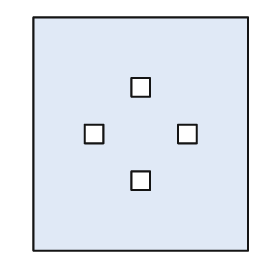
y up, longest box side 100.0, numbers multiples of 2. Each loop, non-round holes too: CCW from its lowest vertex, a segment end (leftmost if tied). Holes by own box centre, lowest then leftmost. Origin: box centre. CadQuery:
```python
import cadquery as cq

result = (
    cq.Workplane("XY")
    .moveTo(-46.0, -50.0)
    .lineTo(46.0, -50.0)
    .lineTo(46.0, 50.0)
    .lineTo(-46.0, 50.0)
    .close()
    .moveTo(-4.0, -24.0)
    .lineTo(4.0, -24.0)
    .lineTo(4.0, -16.0)
    .lineTo(-4.0, -16.0)
    .close()
    .moveTo(-24.0, -4.0)
    .lineTo(-16.0, -4.0)
    .lineTo(-16.0, 4.0)
    .lineTo(-24.0, 4.0)
    .close()
    .moveTo(16.0, -4.0)
    .lineTo(24.0, -4.0)
    .lineTo(24.0, 4.0)
    .lineTo(16.0, 4.0)
    .close()
    .moveTo(-4.0, 16.0)
    .lineTo(4.0, 16.0)
    .lineTo(4.0, 24.0)
    .lineTo(-4.0, 24.0)
    .close()
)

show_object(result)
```